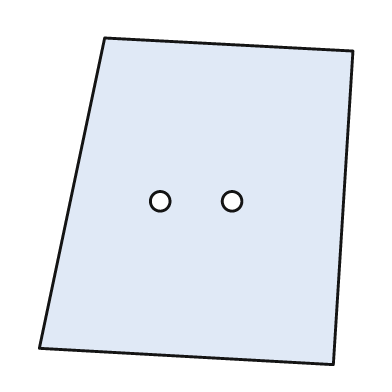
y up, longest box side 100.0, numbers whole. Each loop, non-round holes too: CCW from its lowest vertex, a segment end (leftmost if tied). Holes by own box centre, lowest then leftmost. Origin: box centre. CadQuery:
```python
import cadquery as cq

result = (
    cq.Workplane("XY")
    .moveTo(42.0, -50.0)
    .lineTo(48.0, 46.0)
    .lineTo(-28.0, 50.0)
    .lineTo(-48.0, -45.0)
    .close()
    .moveTo(-11.0, 0.0)
    .circle(3.0)
    .moveTo(11.0, 0.0)
    .circle(3.0)
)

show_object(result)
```